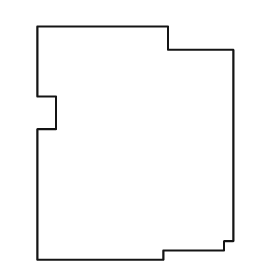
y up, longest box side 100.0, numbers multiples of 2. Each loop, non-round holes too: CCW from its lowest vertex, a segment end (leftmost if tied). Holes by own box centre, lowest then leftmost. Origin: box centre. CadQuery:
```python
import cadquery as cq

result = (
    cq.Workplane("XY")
    .moveTo(-42.0, -50.0)
    .lineTo(12.0, -50.0)
    .lineTo(12.0, -46.0)
    .lineTo(38.0, -46.0)
    .lineTo(38.0, -42.0)
    .lineTo(42.0, -42.0)
    .lineTo(42.0, 40.0)
    .lineTo(14.0, 40.0)
    .lineTo(14.0, 50.0)
    .lineTo(-42.0, 50.0)
    .lineTo(-42.0, 20.0)
    .lineTo(-34.0, 20.0)
    .lineTo(-34.0, 6.0)
    .lineTo(-42.0, 6.0)
    .close()
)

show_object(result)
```